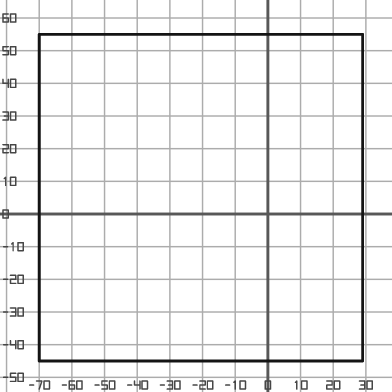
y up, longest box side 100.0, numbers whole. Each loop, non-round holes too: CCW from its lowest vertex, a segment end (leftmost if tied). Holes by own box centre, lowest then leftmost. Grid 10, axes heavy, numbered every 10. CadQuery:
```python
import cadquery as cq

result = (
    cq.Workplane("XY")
    .moveTo(-70.0, -45.0)
    .lineTo(29.0, -45.0)
    .lineTo(29.0, 55.0)
    .lineTo(-70.0, 55.0)
    .close()
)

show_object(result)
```